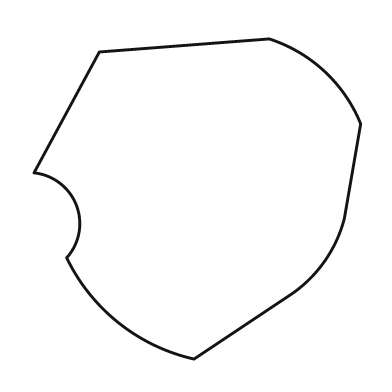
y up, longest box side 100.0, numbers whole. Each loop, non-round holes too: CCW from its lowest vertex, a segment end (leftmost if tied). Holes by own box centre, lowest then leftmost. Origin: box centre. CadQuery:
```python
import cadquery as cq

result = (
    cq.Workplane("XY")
    .moveTo(-1.0, -49.0)
    .lineTo(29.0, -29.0)
    .threePointArc((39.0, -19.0), (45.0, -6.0))
    .lineTo(50.0, 23.0)
    .threePointArc((39.0, 39.0), (22.0, 49.0))
    .lineTo(-30.0, 45.0)
    .lineTo(-50.0, 8.0)
    .threePointArc((-37.0, -2.0), (-40.0, -18.0))
    .threePointArc((-24.0, -38.0), (-1.0, -49.0))
    .close()
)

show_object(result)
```